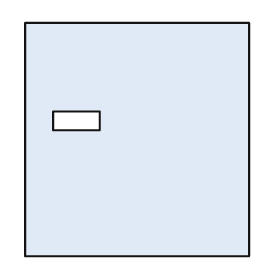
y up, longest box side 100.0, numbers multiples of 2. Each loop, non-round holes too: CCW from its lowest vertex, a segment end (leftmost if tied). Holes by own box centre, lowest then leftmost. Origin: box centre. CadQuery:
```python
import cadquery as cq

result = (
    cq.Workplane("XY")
    .moveTo(-48.0, -50.0)
    .lineTo(48.0, -50.0)
    .lineTo(48.0, 50.0)
    .lineTo(-48.0, 50.0)
    .close()
    .moveTo(-36.0, 4.0)
    .lineTo(-16.0, 4.0)
    .lineTo(-16.0, 12.0)
    .lineTo(-36.0, 12.0)
    .close()
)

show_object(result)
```